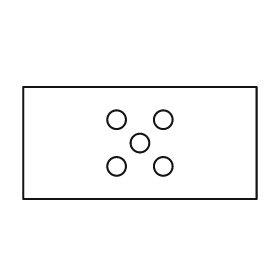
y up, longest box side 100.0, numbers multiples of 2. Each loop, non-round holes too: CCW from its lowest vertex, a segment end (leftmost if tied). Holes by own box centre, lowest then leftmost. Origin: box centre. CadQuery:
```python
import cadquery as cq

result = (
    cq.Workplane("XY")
    .moveTo(-50.0, -24.0)
    .lineTo(50.0, -24.0)
    .lineTo(50.0, 24.0)
    .lineTo(-50.0, 24.0)
    .close()
    .moveTo(-10.0, -10.0)
    .circle(4.0)
    .moveTo(10.0, -10.0)
    .circle(4.0)
    .moveTo(0.0, 0.0)
    .circle(4.0)
    .moveTo(-10.0, 10.0)
    .circle(4.0)
    .moveTo(10.0, 10.0)
    .circle(4.0)
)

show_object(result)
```